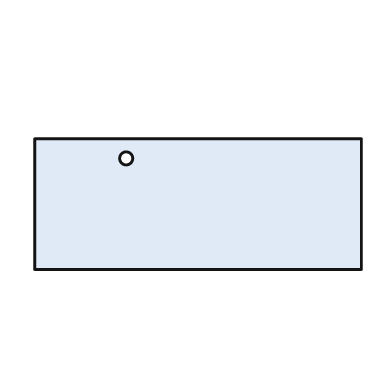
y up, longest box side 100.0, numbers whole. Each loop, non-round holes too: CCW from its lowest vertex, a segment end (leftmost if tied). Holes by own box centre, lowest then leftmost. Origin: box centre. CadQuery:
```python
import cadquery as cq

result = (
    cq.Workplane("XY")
    .moveTo(-50.0, -20.0)
    .lineTo(50.0, -20.0)
    .lineTo(50.0, 20.0)
    .lineTo(-50.0, 20.0)
    .close()
    .moveTo(-22.0, 14.0)
    .circle(2.0)
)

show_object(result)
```